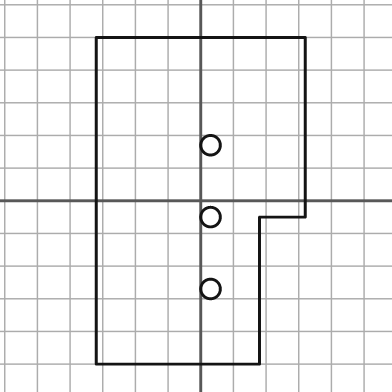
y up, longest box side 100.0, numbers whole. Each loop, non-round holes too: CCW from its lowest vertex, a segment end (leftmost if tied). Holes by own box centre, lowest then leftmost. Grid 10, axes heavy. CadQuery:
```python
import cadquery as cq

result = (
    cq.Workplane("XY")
    .moveTo(-32.0, -50.0)
    .lineTo(18.0, -50.0)
    .lineTo(18.0, -5.0)
    .lineTo(32.0, -5.0)
    .lineTo(32.0, 50.0)
    .lineTo(-32.0, 50.0)
    .close()
    .moveTo(3.0, -27.0)
    .circle(3.0)
    .moveTo(3.0, -5.0)
    .circle(3.0)
    .moveTo(3.0, 17.0)
    .circle(3.0)
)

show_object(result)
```